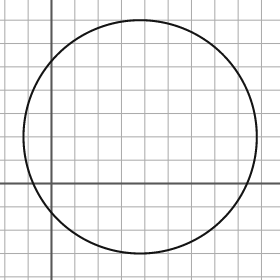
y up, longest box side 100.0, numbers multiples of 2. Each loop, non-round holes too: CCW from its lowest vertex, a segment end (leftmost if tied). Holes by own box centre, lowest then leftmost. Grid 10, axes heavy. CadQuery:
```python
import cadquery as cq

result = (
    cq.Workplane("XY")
    .moveTo(38.0, 20.0)
    .circle(50.0)
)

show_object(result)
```